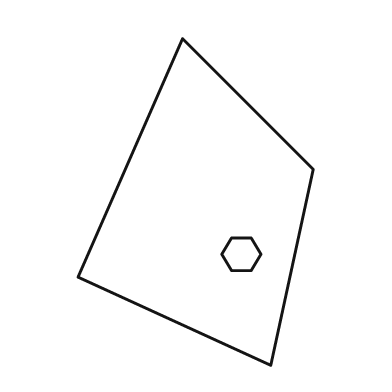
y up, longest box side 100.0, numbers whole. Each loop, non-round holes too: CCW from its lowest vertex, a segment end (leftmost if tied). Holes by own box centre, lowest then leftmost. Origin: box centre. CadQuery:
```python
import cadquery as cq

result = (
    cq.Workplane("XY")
    .moveTo(23.0, -50.0)
    .lineTo(36.0, 10.0)
    .lineTo(-4.0, 50.0)
    .lineTo(-36.0, -23.0)
    .close()
    .moveTo(11.0, -21.0)
    .lineTo(17.0, -21.0)
    .lineTo(20.0, -16.0)
    .lineTo(17.0, -11.0)
    .lineTo(11.0, -11.0)
    .lineTo(8.0, -16.0)
    .close()
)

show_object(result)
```